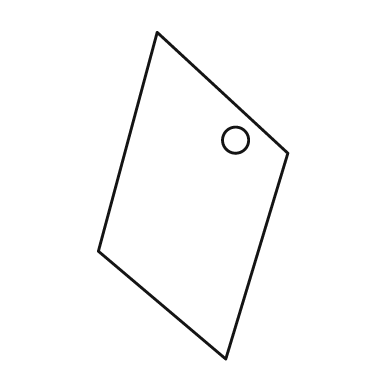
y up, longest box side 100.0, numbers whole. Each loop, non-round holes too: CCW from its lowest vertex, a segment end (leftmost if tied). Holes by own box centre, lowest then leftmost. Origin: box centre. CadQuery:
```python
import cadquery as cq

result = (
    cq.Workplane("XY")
    .moveTo(10.0, -50.0)
    .lineTo(29.0, 13.0)
    .lineTo(-11.0, 50.0)
    .lineTo(-29.0, -17.0)
    .close()
    .moveTo(13.0, 17.0)
    .circle(4.0)
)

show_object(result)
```